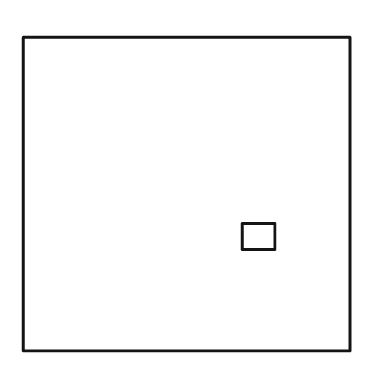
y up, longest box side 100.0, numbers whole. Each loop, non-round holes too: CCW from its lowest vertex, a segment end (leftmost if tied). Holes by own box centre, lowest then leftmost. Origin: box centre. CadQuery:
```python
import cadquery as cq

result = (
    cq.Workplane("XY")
    .moveTo(-50.0, -48.0)
    .lineTo(50.0, -48.0)
    .lineTo(50.0, 48.0)
    .lineTo(-50.0, 48.0)
    .close()
    .moveTo(17.0, -17.0)
    .lineTo(27.0, -17.0)
    .lineTo(27.0, -9.0)
    .lineTo(17.0, -9.0)
    .close()
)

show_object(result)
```